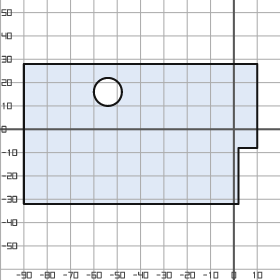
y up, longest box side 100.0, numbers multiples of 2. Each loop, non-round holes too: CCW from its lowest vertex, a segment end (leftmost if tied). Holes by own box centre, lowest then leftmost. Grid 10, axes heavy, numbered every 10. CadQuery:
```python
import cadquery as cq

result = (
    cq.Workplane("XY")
    .moveTo(-90.0, -32.0)
    .lineTo(2.0, -32.0)
    .lineTo(2.0, -8.0)
    .lineTo(10.0, -8.0)
    .lineTo(10.0, 28.0)
    .lineTo(-90.0, 28.0)
    .close()
    .moveTo(-54.0, 16.0)
    .circle(6.0)
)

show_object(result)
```